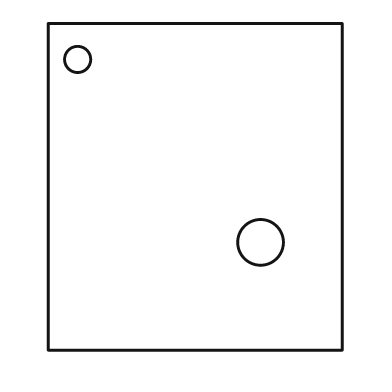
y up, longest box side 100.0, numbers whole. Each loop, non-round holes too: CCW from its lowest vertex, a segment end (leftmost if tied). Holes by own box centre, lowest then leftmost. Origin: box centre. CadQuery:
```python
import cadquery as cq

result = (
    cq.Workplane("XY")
    .moveTo(-45.0, -50.0)
    .lineTo(45.0, -50.0)
    .lineTo(45.0, 50.0)
    .lineTo(-45.0, 50.0)
    .close()
    .moveTo(20.0, -17.0)
    .circle(7.0)
    .moveTo(-36.0, 39.0)
    .circle(4.0)
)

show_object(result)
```